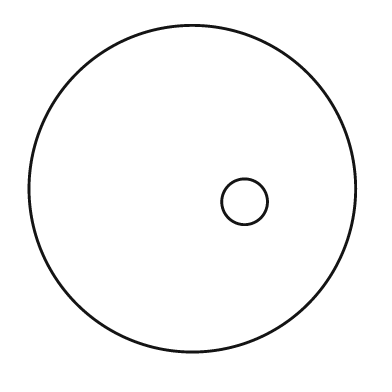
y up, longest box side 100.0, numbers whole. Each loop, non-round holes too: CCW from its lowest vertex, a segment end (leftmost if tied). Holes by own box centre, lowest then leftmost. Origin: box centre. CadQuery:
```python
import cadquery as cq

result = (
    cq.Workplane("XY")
    .moveTo(0.0, 0.0)
    .circle(50.0)
    .moveTo(16.0, -4.0)
    .circle(7.0)
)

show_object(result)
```